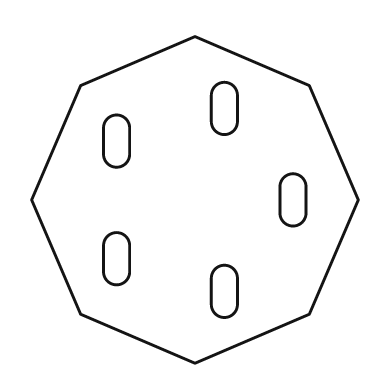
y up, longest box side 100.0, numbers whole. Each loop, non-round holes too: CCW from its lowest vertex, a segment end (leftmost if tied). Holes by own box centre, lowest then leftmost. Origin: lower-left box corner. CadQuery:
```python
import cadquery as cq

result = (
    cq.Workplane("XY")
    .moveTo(50.0, 0.0)
    .lineTo(85.0, 15.0)
    .lineTo(100.0, 50.0)
    .lineTo(85.0, 85.0)
    .lineTo(50.0, 100.0)
    .lineTo(15.0, 85.0)
    .lineTo(0.0, 50.0)
    .lineTo(15.0, 15.0)
    .close()
    .moveTo(55.0, 18.0)
    .threePointArc((59.0, 14.0), (63.0, 18.0))
    .lineTo(63.0, 26.0)
    .threePointArc((59.0, 30.0), (55.0, 26.0))
    .close()
    .moveTo(22.0, 28.0)
    .threePointArc((26.0, 24.0), (30.0, 28.0))
    .lineTo(30.0, 36.0)
    .threePointArc((26.0, 40.0), (22.0, 36.0))
    .close()
    .moveTo(76.0, 46.0)
    .threePointArc((80.0, 42.0), (84.0, 46.0))
    .lineTo(84.0, 54.0)
    .threePointArc((80.0, 58.0), (76.0, 54.0))
    .close()
    .moveTo(22.0, 64.0)
    .threePointArc((26.0, 60.0), (30.0, 64.0))
    .lineTo(30.0, 72.0)
    .threePointArc((26.0, 76.0), (22.0, 72.0))
    .close()
    .moveTo(55.0, 74.0)
    .threePointArc((59.0, 70.0), (63.0, 74.0))
    .lineTo(63.0, 82.0)
    .threePointArc((59.0, 86.0), (55.0, 82.0))
    .close()
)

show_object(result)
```